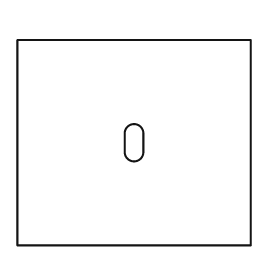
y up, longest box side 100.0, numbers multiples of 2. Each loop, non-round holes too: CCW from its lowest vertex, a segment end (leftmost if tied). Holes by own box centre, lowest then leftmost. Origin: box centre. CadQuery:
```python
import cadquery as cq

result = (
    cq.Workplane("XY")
    .moveTo(-50.0, -44.0)
    .lineTo(50.0, -44.0)
    .lineTo(50.0, 44.0)
    .lineTo(-50.0, 44.0)
    .close()
    .moveTo(-4.0, -4.0)
    .threePointArc((0.0, -8.0), (4.0, -4.0))
    .lineTo(4.0, 4.0)
    .threePointArc((0.0, 8.0), (-4.0, 4.0))
    .close()
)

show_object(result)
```